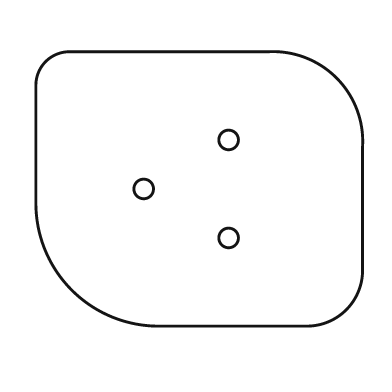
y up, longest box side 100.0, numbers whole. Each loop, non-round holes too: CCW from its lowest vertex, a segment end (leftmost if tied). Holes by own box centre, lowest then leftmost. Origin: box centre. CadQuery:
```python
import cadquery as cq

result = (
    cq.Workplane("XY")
    .moveTo(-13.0, -42.0)
    .lineTo(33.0, -42.0)
    .threePointArc((45.0, -37.0), (50.0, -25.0))
    .lineTo(50.0, 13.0)
    .threePointArc((42.0, 34.0), (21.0, 42.0))
    .lineTo(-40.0, 42.0)
    .threePointArc((-47.0, 39.0), (-50.0, 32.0))
    .lineTo(-50.0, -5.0)
    .threePointArc((-39.0, -31.0), (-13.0, -42.0))
    .close()
    .moveTo(9.0, -15.0)
    .circle(3.0)
    .moveTo(-17.0, 0.0)
    .circle(3.0)
    .moveTo(9.0, 15.0)
    .circle(3.0)
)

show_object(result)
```